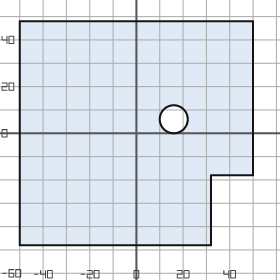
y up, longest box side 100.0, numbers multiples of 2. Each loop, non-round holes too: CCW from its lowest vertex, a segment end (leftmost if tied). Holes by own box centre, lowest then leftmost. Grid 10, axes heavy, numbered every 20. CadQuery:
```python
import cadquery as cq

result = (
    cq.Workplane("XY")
    .moveTo(-50.0, -48.0)
    .lineTo(32.0, -48.0)
    .lineTo(32.0, -18.0)
    .lineTo(50.0, -18.0)
    .lineTo(50.0, 48.0)
    .lineTo(-50.0, 48.0)
    .close()
    .moveTo(16.0, 6.0)
    .circle(6.0)
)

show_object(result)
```